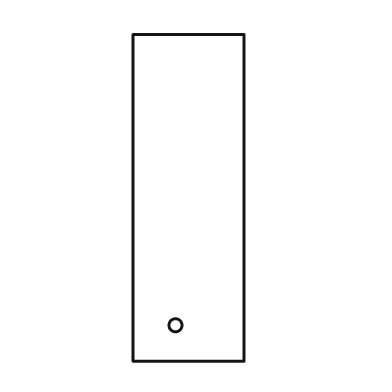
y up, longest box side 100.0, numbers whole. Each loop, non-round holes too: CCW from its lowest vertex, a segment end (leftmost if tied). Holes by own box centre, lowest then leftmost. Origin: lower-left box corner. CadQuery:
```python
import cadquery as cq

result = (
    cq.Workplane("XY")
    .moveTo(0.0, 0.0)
    .lineTo(34.0, 0.0)
    .lineTo(34.0, 100.0)
    .lineTo(0.0, 100.0)
    .close()
    .moveTo(13.0, 11.0)
    .circle(2.0)
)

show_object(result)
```